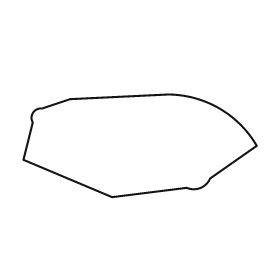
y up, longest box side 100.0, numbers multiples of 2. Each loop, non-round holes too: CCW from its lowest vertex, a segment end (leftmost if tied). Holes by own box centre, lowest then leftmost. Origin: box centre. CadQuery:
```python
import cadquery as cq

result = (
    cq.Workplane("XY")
    .moveTo(-12.0, -22.0)
    .lineTo(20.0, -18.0)
    .threePointArc((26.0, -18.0), (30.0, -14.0))
    .lineTo(50.0, 0.0)
    .threePointArc((34.0, 16.0), (12.0, 22.0))
    .lineTo(-30.0, 20.0)
    .lineTo(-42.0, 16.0)
    .threePointArc((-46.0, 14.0), (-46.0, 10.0))
    .lineTo(-50.0, -6.0)
    .close()
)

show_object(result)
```